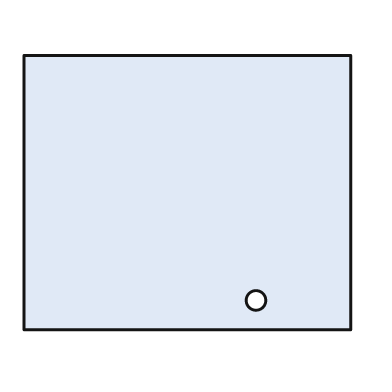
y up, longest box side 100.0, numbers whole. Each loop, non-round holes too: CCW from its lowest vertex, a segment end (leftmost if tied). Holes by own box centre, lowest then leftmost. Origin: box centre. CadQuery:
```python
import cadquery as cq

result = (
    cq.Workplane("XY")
    .moveTo(-50.0, -42.0)
    .lineTo(50.0, -42.0)
    .lineTo(50.0, 42.0)
    .lineTo(-50.0, 42.0)
    .close()
    .moveTo(21.0, -33.0)
    .circle(3.0)
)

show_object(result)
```